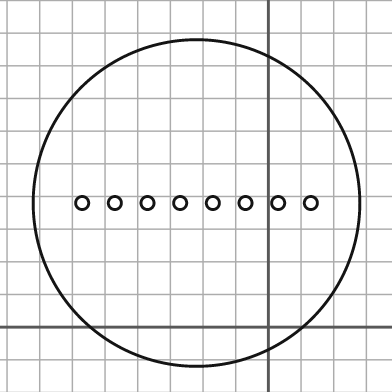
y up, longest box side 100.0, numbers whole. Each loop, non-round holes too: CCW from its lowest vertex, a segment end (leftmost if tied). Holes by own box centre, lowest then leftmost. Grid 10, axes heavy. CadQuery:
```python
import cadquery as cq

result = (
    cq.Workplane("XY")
    .moveTo(-22.0, 38.0)
    .circle(50.0)
    .moveTo(-57.0, 38.0)
    .circle(2.0)
    .moveTo(-47.0, 38.0)
    .circle(2.0)
    .moveTo(-37.0, 38.0)
    .circle(2.0)
    .moveTo(-27.0, 38.0)
    .circle(2.0)
    .moveTo(-17.0, 38.0)
    .circle(2.0)
    .moveTo(-7.0, 38.0)
    .circle(2.0)
    .moveTo(3.0, 38.0)
    .circle(2.0)
    .moveTo(13.0, 38.0)
    .circle(2.0)
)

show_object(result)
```